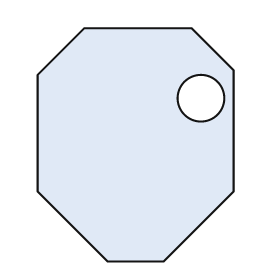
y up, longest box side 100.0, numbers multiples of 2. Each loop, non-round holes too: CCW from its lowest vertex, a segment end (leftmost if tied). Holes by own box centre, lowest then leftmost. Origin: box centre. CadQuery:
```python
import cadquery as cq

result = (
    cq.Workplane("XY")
    .moveTo(-12.0, -50.0)
    .lineTo(12.0, -50.0)
    .lineTo(42.0, -20.0)
    .lineTo(42.0, 32.0)
    .lineTo(24.0, 50.0)
    .lineTo(-22.0, 50.0)
    .lineTo(-42.0, 30.0)
    .lineTo(-42.0, -20.0)
    .close()
    .moveTo(28.0, 20.0)
    .circle(10.0)
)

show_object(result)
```